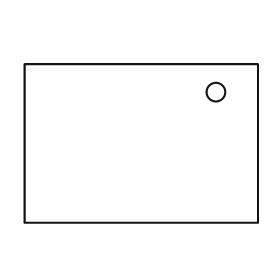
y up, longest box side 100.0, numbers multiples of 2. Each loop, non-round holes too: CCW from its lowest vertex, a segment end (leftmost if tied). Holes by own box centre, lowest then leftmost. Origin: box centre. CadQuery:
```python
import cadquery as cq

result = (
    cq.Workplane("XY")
    .moveTo(-50.0, -34.0)
    .lineTo(50.0, -34.0)
    .lineTo(50.0, 34.0)
    .lineTo(-50.0, 34.0)
    .close()
    .moveTo(32.0, 22.0)
    .circle(4.0)
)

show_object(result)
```